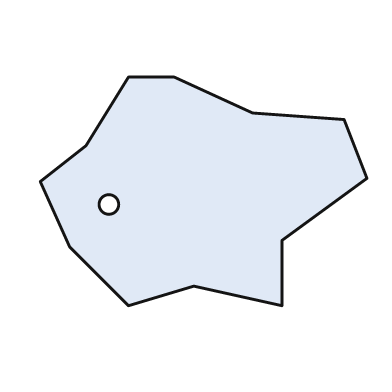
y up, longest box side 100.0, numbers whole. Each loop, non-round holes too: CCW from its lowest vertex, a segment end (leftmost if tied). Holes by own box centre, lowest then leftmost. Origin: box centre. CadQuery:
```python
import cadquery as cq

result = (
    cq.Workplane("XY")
    .moveTo(-23.0, -35.0)
    .lineTo(-3.0, -29.0)
    .lineTo(24.0, -35.0)
    .lineTo(24.0, -15.0)
    .lineTo(50.0, 4.0)
    .lineTo(43.0, 22.0)
    .lineTo(15.0, 24.0)
    .lineTo(-9.0, 35.0)
    .lineTo(-23.0, 35.0)
    .lineTo(-36.0, 14.0)
    .lineTo(-50.0, 3.0)
    .lineTo(-41.0, -17.0)
    .close()
    .moveTo(-29.0, -4.0)
    .circle(3.0)
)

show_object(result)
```